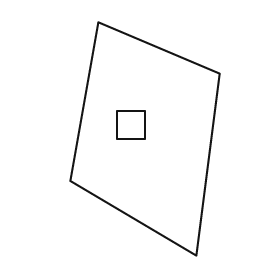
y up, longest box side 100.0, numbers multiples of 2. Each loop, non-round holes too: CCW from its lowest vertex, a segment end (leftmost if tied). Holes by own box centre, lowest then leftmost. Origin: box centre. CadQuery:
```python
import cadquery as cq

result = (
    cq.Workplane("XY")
    .moveTo(22.0, -50.0)
    .lineTo(32.0, 28.0)
    .lineTo(-20.0, 50.0)
    .lineTo(-32.0, -18.0)
    .close()
    .moveTo(-12.0, 0.0)
    .lineTo(0.0, 0.0)
    .lineTo(0.0, 12.0)
    .lineTo(-12.0, 12.0)
    .close()
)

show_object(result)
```